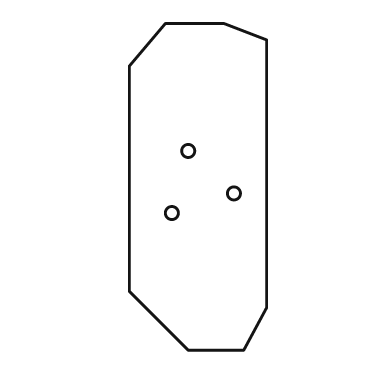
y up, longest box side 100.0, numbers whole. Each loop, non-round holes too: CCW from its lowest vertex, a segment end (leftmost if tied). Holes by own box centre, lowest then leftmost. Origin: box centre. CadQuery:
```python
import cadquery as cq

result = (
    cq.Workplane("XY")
    .moveTo(-3.0, -50.0)
    .lineTo(14.0, -50.0)
    .lineTo(21.0, -37.0)
    .lineTo(21.0, 45.0)
    .lineTo(8.0, 50.0)
    .lineTo(-10.0, 50.0)
    .lineTo(-21.0, 37.0)
    .lineTo(-21.0, -32.0)
    .close()
    .moveTo(-8.0, -8.0)
    .circle(2.0)
    .moveTo(11.0, -2.0)
    .circle(2.0)
    .moveTo(-3.0, 11.0)
    .circle(2.0)
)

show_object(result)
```